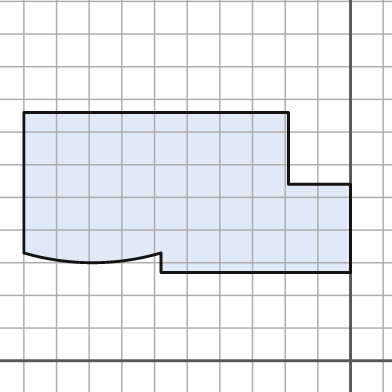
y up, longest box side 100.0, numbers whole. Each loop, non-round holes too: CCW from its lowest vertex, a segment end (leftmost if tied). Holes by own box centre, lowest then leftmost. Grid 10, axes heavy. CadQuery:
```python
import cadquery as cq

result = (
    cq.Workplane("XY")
    .moveTo(-58.0, 27.0)
    .lineTo(0.0, 27.0)
    .lineTo(0.0, 54.0)
    .lineTo(-19.0, 54.0)
    .lineTo(-19.0, 76.0)
    .lineTo(-100.0, 76.0)
    .lineTo(-100.0, 33.0)
    .threePointArc((-79.0, 30.0), (-58.0, 33.0))
    .close()
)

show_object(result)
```